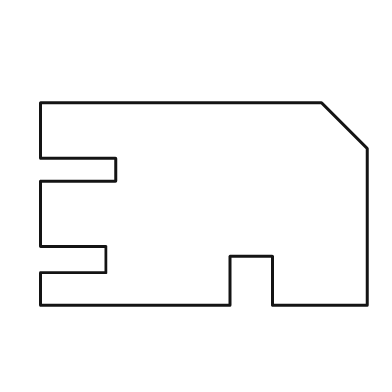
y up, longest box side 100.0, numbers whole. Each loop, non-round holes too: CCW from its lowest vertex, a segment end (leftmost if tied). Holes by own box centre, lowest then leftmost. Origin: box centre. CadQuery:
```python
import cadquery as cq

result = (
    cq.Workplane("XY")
    .moveTo(-50.0, -31.0)
    .lineTo(8.0, -31.0)
    .lineTo(8.0, -16.0)
    .lineTo(21.0, -16.0)
    .lineTo(21.0, -31.0)
    .lineTo(50.0, -31.0)
    .lineTo(50.0, 17.0)
    .lineTo(36.0, 31.0)
    .lineTo(-50.0, 31.0)
    .lineTo(-50.0, 14.0)
    .lineTo(-27.0, 14.0)
    .lineTo(-27.0, 7.0)
    .lineTo(-50.0, 7.0)
    .lineTo(-50.0, -13.0)
    .lineTo(-30.0, -13.0)
    .lineTo(-30.0, -21.0)
    .lineTo(-50.0, -21.0)
    .close()
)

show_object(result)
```